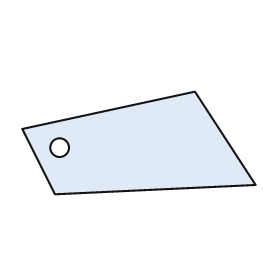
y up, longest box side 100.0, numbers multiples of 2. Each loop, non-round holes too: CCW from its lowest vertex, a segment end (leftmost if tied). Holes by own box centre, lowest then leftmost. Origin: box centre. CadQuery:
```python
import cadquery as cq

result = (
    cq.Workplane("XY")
    .moveTo(-36.0, -22.0)
    .lineTo(50.0, -18.0)
    .lineTo(24.0, 22.0)
    .lineTo(-50.0, 6.0)
    .close()
    .moveTo(-34.0, -2.0)
    .circle(4.0)
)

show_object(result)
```